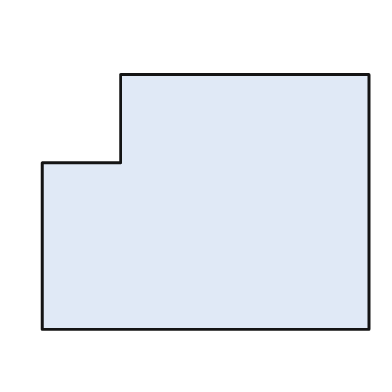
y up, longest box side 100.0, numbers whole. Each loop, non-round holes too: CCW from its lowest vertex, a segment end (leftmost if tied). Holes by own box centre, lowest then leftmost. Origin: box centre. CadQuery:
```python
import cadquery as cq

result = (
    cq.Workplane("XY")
    .moveTo(-50.0, -39.0)
    .lineTo(50.0, -39.0)
    .lineTo(50.0, 39.0)
    .lineTo(-26.0, 39.0)
    .lineTo(-26.0, 12.0)
    .lineTo(-50.0, 12.0)
    .close()
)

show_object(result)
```